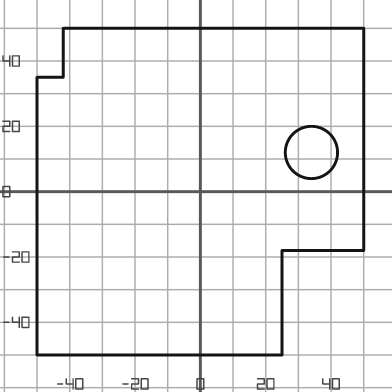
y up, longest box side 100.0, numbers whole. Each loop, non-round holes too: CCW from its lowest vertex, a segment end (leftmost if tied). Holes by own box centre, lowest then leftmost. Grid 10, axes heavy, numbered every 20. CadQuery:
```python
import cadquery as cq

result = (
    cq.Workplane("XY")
    .moveTo(-50.0, -50.0)
    .lineTo(25.0, -50.0)
    .lineTo(25.0, -18.0)
    .lineTo(50.0, -18.0)
    .lineTo(50.0, 50.0)
    .lineTo(-42.0, 50.0)
    .lineTo(-42.0, 35.0)
    .lineTo(-50.0, 35.0)
    .close()
    .moveTo(34.0, 12.0)
    .circle(8.0)
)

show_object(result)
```